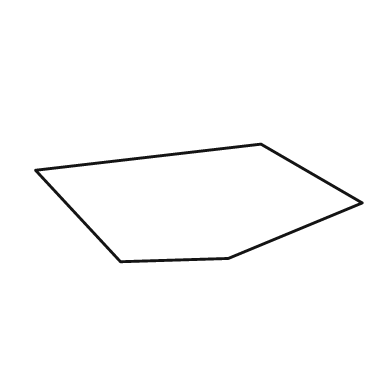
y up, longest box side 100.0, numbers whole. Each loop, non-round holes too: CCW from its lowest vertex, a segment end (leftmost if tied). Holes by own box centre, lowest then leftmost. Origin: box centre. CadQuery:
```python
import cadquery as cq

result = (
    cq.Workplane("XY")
    .moveTo(-24.0, -18.0)
    .lineTo(9.0, -17.0)
    .lineTo(50.0, 0.0)
    .lineTo(19.0, 18.0)
    .lineTo(-50.0, 10.0)
    .close()
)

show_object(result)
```